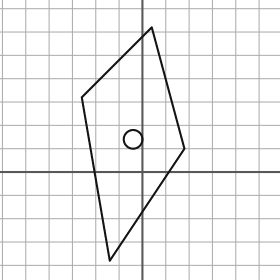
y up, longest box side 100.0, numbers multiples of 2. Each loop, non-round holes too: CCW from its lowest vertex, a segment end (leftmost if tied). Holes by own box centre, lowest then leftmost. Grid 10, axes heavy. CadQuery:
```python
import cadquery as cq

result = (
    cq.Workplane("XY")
    .moveTo(-14.0, -38.0)
    .lineTo(18.0, 10.0)
    .lineTo(4.0, 62.0)
    .lineTo(-26.0, 32.0)
    .close()
    .moveTo(-4.0, 14.0)
    .circle(4.0)
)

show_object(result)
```